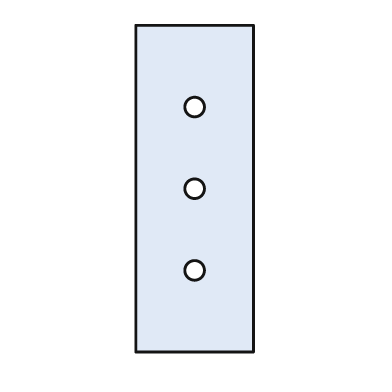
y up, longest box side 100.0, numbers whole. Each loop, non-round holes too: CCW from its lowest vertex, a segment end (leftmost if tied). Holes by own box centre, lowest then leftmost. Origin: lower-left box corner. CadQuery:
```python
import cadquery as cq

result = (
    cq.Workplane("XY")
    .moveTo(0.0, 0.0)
    .lineTo(36.0, 0.0)
    .lineTo(36.0, 100.0)
    .lineTo(0.0, 100.0)
    .close()
    .moveTo(18.0, 25.0)
    .circle(3.0)
    .moveTo(18.0, 50.0)
    .circle(3.0)
    .moveTo(18.0, 75.0)
    .circle(3.0)
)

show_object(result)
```